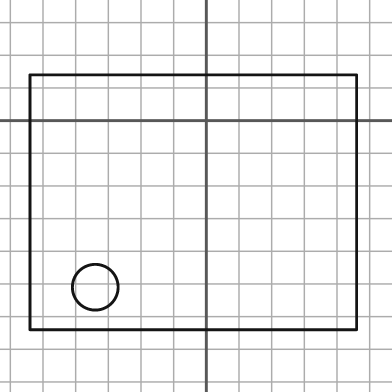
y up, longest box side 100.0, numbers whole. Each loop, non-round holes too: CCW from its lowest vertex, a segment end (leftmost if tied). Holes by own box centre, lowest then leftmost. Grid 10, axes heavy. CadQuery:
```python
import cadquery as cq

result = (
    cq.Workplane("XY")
    .moveTo(-54.0, -64.0)
    .lineTo(46.0, -64.0)
    .lineTo(46.0, 14.0)
    .lineTo(-54.0, 14.0)
    .close()
    .moveTo(-34.0, -51.0)
    .circle(7.0)
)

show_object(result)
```